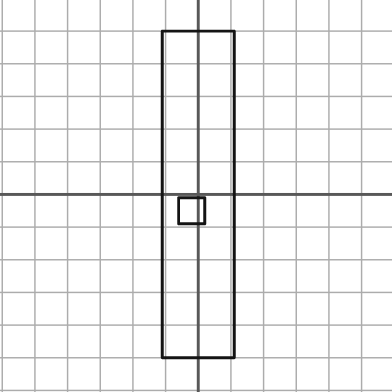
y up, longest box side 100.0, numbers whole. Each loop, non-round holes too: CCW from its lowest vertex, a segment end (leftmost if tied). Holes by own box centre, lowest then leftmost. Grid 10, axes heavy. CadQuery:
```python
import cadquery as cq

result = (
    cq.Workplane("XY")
    .moveTo(-11.0, -50.0)
    .lineTo(11.0, -50.0)
    .lineTo(11.0, 50.0)
    .lineTo(-11.0, 50.0)
    .close()
    .moveTo(-6.0, -9.0)
    .lineTo(2.0, -9.0)
    .lineTo(2.0, -1.0)
    .lineTo(-6.0, -1.0)
    .close()
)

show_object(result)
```